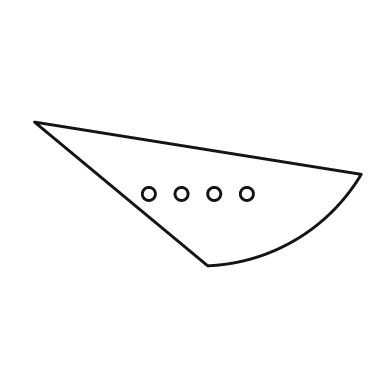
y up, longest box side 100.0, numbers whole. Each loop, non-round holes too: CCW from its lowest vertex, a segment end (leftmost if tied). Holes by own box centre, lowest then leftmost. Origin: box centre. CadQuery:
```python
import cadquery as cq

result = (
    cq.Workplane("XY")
    .moveTo(3.0, -22.0)
    .threePointArc((30.0, -14.0), (50.0, 6.0))
    .lineTo(-50.0, 22.0)
    .close()
    .moveTo(-15.0, 0.0)
    .circle(2.0)
    .moveTo(-5.0, 0.0)
    .circle(2.0)
    .moveTo(5.0, 0.0)
    .circle(2.0)
    .moveTo(15.0, 0.0)
    .circle(2.0)
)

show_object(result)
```